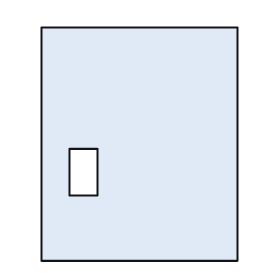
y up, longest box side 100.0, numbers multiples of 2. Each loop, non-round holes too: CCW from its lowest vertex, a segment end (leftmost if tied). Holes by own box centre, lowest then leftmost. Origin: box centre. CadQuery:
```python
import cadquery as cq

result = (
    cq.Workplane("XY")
    .moveTo(-42.0, -50.0)
    .lineTo(42.0, -50.0)
    .lineTo(42.0, 50.0)
    .lineTo(-42.0, 50.0)
    .close()
    .moveTo(-30.0, -22.0)
    .lineTo(-18.0, -22.0)
    .lineTo(-18.0, -2.0)
    .lineTo(-30.0, -2.0)
    .close()
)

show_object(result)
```